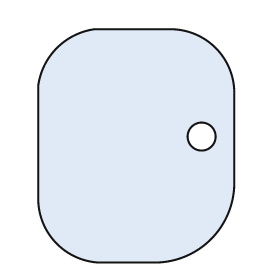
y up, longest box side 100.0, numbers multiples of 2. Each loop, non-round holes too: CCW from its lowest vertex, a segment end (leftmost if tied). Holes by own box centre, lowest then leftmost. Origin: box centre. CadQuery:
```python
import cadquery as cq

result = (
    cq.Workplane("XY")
    .moveTo(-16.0, -50.0)
    .lineTo(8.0, -50.0)
    .threePointArc((32.0, -40.0), (42.0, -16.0))
    .lineTo(42.0, 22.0)
    .threePointArc((34.0, 42.0), (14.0, 50.0))
    .lineTo(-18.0, 50.0)
    .threePointArc((-34.0, 42.0), (-42.0, 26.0))
    .lineTo(-42.0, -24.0)
    .threePointArc((-34.0, -42.0), (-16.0, -50.0))
    .close()
    .moveTo(28.0, 4.0)
    .circle(6.0)
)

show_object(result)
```